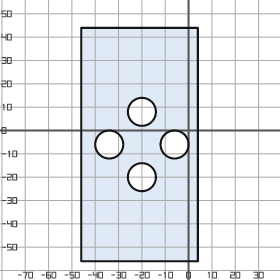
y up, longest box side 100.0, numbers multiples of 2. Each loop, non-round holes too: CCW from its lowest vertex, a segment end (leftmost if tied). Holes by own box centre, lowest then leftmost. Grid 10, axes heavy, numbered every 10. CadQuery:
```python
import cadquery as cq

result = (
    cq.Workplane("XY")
    .moveTo(-46.0, -56.0)
    .lineTo(4.0, -56.0)
    .lineTo(4.0, 44.0)
    .lineTo(-46.0, 44.0)
    .close()
    .moveTo(-20.0, -20.0)
    .circle(6.0)
    .moveTo(-34.0, -6.0)
    .circle(6.0)
    .moveTo(-6.0, -6.0)
    .circle(6.0)
    .moveTo(-20.0, 8.0)
    .circle(6.0)
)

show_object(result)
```